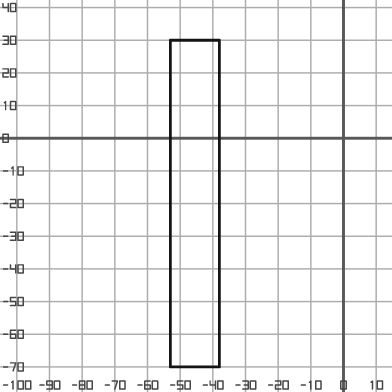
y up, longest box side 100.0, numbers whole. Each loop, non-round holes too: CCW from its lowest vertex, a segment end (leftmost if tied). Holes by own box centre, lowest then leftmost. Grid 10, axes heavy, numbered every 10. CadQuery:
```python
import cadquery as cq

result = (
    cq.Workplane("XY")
    .moveTo(-53.0, -70.0)
    .lineTo(-38.0, -70.0)
    .lineTo(-38.0, 30.0)
    .lineTo(-53.0, 30.0)
    .close()
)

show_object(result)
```